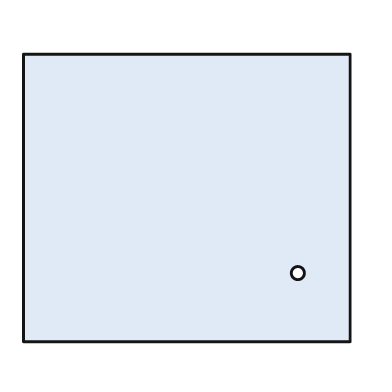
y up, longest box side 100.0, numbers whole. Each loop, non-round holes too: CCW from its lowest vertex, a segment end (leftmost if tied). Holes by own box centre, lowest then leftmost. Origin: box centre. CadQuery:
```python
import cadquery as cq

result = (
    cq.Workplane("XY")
    .moveTo(-50.0, -44.0)
    .lineTo(50.0, -44.0)
    .lineTo(50.0, 44.0)
    .lineTo(-50.0, 44.0)
    .close()
    .moveTo(34.0, -23.0)
    .circle(2.0)
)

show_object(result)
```